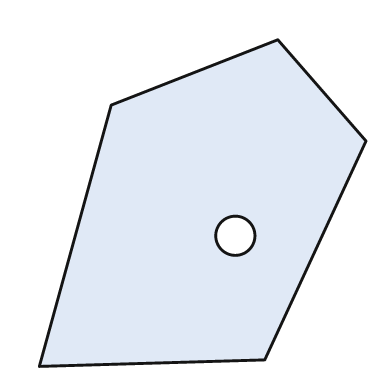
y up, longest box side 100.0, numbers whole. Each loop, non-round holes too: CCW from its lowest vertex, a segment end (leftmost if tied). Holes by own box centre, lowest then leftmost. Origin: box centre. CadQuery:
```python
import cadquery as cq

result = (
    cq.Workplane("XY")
    .moveTo(-50.0, -50.0)
    .lineTo(19.0, -48.0)
    .lineTo(50.0, 19.0)
    .lineTo(23.0, 50.0)
    .lineTo(-28.0, 30.0)
    .close()
    .moveTo(10.0, -10.0)
    .circle(6.0)
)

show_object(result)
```